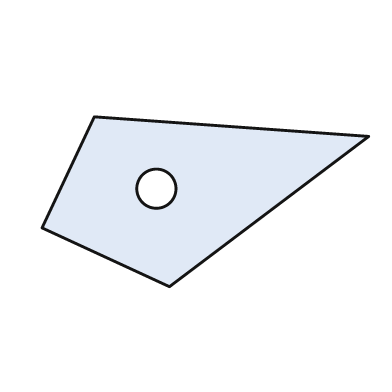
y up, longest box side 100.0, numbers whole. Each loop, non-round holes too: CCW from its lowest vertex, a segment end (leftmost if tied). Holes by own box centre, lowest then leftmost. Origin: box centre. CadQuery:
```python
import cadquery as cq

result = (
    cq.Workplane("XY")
    .moveTo(-11.0, -26.0)
    .lineTo(50.0, 20.0)
    .lineTo(-34.0, 26.0)
    .lineTo(-50.0, -8.0)
    .close()
    .moveTo(-15.0, 4.0)
    .circle(6.0)
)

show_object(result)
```